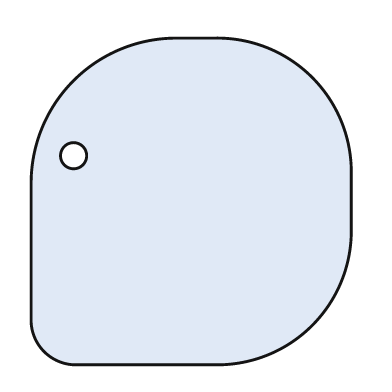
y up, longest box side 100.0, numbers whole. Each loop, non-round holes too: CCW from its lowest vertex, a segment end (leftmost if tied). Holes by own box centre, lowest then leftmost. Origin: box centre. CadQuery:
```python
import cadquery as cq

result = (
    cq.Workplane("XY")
    .moveTo(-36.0, -50.0)
    .lineTo(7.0, -50.0)
    .threePointArc((37.0, -38.0), (49.0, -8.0))
    .lineTo(49.0, 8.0)
    .threePointArc((37.0, 38.0), (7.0, 50.0))
    .lineTo(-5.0, 50.0)
    .threePointArc((-36.0, 37.0), (-49.0, 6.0))
    .lineTo(-49.0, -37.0)
    .threePointArc((-45.0, -46.0), (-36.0, -50.0))
    .close()
    .moveTo(-36.0, 14.0)
    .circle(4.0)
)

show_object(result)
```